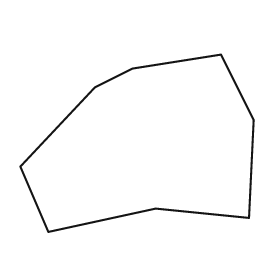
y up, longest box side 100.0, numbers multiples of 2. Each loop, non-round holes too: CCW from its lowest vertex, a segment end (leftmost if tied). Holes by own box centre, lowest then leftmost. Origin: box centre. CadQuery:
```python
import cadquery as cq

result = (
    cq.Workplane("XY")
    .moveTo(-38.0, -38.0)
    .lineTo(8.0, -28.0)
    .lineTo(48.0, -32.0)
    .lineTo(50.0, 10.0)
    .lineTo(36.0, 38.0)
    .lineTo(-2.0, 32.0)
    .lineTo(-18.0, 24.0)
    .lineTo(-50.0, -10.0)
    .close()
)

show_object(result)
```